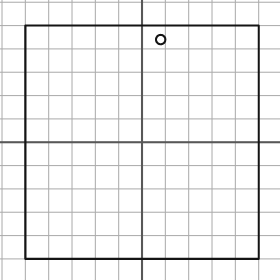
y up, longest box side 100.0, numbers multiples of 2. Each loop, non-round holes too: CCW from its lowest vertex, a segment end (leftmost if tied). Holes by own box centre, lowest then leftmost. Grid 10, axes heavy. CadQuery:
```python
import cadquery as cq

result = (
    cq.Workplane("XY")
    .moveTo(-50.0, -50.0)
    .lineTo(50.0, -50.0)
    .lineTo(50.0, 50.0)
    .lineTo(-50.0, 50.0)
    .close()
    .moveTo(8.0, 44.0)
    .circle(2.0)
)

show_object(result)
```